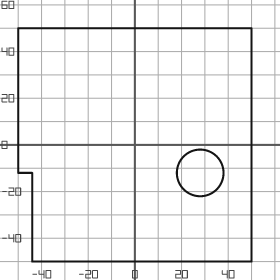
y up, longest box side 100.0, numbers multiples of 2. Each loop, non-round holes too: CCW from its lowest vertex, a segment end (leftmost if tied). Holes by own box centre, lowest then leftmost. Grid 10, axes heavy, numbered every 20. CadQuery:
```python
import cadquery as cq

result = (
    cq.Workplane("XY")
    .moveTo(-44.0, -50.0)
    .lineTo(50.0, -50.0)
    .lineTo(50.0, 50.0)
    .lineTo(-50.0, 50.0)
    .lineTo(-50.0, -12.0)
    .lineTo(-44.0, -12.0)
    .close()
    .moveTo(28.0, -12.0)
    .circle(10.0)
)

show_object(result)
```